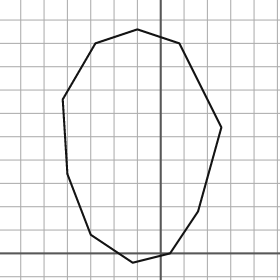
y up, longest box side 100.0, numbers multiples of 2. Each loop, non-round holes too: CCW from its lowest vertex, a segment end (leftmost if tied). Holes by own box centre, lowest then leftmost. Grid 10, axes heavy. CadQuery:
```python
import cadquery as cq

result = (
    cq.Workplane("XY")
    .moveTo(-12.0, -4.0)
    .lineTo(4.0, 0.0)
    .lineTo(16.0, 18.0)
    .lineTo(26.0, 54.0)
    .lineTo(8.0, 90.0)
    .lineTo(-10.0, 96.0)
    .lineTo(-28.0, 90.0)
    .lineTo(-42.0, 66.0)
    .lineTo(-40.0, 34.0)
    .lineTo(-30.0, 8.0)
    .close()
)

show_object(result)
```